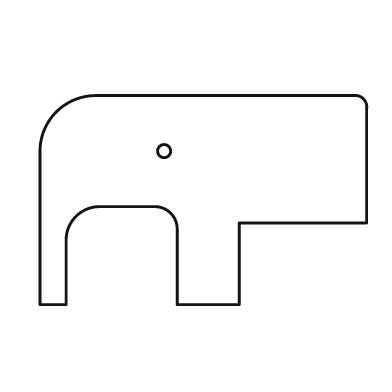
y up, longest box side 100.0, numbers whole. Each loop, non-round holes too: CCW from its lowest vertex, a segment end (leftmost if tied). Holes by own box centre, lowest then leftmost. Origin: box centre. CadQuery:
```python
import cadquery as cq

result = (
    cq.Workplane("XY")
    .moveTo(-50.0, -32.0)
    .lineTo(-42.0, -32.0)
    .lineTo(-42.0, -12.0)
    .threePointArc((-39.0, -5.0), (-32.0, -2.0))
    .lineTo(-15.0, -2.0)
    .threePointArc((-10.0, -4.0), (-8.0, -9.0))
    .lineTo(-8.0, -32.0)
    .lineTo(11.0, -32.0)
    .lineTo(11.0, -7.0)
    .lineTo(50.0, -7.0)
    .lineTo(50.0, 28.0)
    .threePointArc((49.0, 31.0), (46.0, 32.0))
    .lineTo(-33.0, 32.0)
    .threePointArc((-45.0, 27.0), (-50.0, 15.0))
    .close()
    .moveTo(-12.0, 15.0)
    .circle(2.0)
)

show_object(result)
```